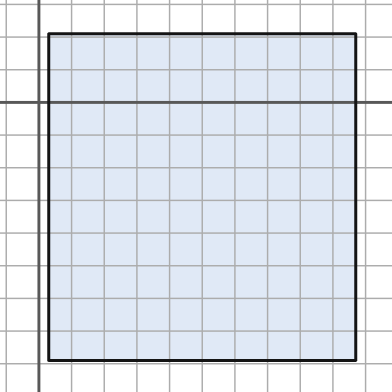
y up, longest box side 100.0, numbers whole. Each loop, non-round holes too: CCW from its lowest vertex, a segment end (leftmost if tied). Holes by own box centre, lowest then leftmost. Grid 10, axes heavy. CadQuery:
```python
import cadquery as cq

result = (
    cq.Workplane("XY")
    .moveTo(3.0, -79.0)
    .lineTo(97.0, -79.0)
    .lineTo(97.0, 21.0)
    .lineTo(3.0, 21.0)
    .close()
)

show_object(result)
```